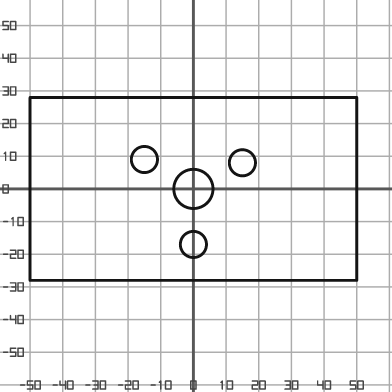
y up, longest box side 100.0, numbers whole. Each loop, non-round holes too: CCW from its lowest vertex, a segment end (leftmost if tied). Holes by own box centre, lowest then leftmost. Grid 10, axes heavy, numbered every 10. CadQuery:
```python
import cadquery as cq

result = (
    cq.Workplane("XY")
    .moveTo(-50.0, -28.0)
    .lineTo(50.0, -28.0)
    .lineTo(50.0, 28.0)
    .lineTo(-50.0, 28.0)
    .close()
    .moveTo(0.0, -17.0)
    .circle(4.0)
    .moveTo(0.0, 0.0)
    .circle(6.0)
    .moveTo(15.0, 8.0)
    .circle(4.0)
    .moveTo(-15.0, 9.0)
    .circle(4.0)
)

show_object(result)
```